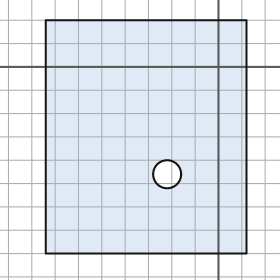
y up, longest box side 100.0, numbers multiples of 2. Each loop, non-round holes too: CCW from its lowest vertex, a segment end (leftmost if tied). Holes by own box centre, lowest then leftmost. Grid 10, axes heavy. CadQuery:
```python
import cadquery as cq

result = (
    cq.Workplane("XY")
    .moveTo(-74.0, -80.0)
    .lineTo(12.0, -80.0)
    .lineTo(12.0, 20.0)
    .lineTo(-74.0, 20.0)
    .close()
    .moveTo(-22.0, -46.0)
    .circle(6.0)
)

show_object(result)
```